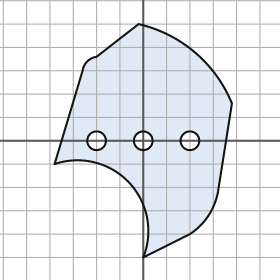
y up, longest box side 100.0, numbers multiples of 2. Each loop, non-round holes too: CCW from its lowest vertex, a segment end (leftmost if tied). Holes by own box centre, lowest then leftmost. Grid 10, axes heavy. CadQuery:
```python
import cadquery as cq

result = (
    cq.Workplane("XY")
    .moveTo(0.0, -50.0)
    .lineTo(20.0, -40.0)
    .threePointArc((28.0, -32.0), (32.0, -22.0))
    .lineTo(38.0, 16.0)
    .threePointArc((22.0, 38.0), (-2.0, 50.0))
    .lineTo(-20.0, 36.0)
    .threePointArc((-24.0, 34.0), (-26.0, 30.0))
    .lineTo(-38.0, -10.0)
    .threePointArc((-6.0, -18.0), (0.0, -50.0))
    .close()
    .moveTo(-20.0, 0.0)
    .circle(4.0)
    .moveTo(0.0, 0.0)
    .circle(4.0)
    .moveTo(20.0, 0.0)
    .circle(4.0)
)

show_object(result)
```